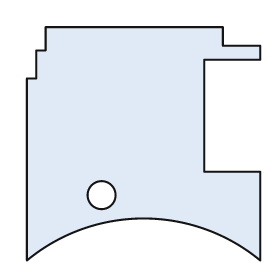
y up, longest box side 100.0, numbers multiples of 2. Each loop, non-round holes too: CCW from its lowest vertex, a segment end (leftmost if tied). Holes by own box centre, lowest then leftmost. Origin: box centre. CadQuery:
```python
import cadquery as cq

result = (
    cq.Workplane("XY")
    .moveTo(-50.0, -50.0)
    .threePointArc((0.0, -32.0), (50.0, -50.0))
    .lineTo(50.0, -12.0)
    .lineTo(26.0, -12.0)
    .lineTo(26.0, 36.0)
    .lineTo(50.0, 36.0)
    .lineTo(50.0, 42.0)
    .lineTo(34.0, 42.0)
    .lineTo(34.0, 50.0)
    .lineTo(-42.0, 50.0)
    .lineTo(-42.0, 40.0)
    .lineTo(-46.0, 40.0)
    .lineTo(-46.0, 28.0)
    .lineTo(-50.0, 28.0)
    .close()
    .moveTo(-18.0, -22.0)
    .circle(6.0)
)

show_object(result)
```